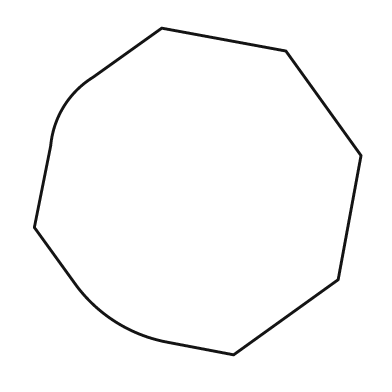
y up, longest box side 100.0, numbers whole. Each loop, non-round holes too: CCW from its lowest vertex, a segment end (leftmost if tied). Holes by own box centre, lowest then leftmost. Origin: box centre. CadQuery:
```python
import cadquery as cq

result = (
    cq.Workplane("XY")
    .moveTo(11.0, -50.0)
    .lineTo(43.0, -27.0)
    .lineTo(50.0, 11.0)
    .lineTo(27.0, 43.0)
    .lineTo(-11.0, 50.0)
    .lineTo(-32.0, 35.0)
    .threePointArc((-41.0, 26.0), (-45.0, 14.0))
    .lineTo(-50.0, -11.0)
    .lineTo(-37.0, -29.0)
    .threePointArc((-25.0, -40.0), (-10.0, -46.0))
    .close()
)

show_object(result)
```